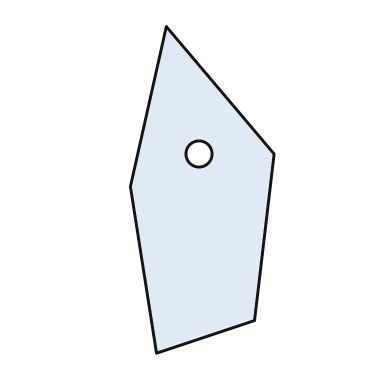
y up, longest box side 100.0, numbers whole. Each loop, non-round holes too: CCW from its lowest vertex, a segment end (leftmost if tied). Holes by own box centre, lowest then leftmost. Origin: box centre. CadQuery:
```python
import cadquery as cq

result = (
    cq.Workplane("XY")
    .moveTo(-14.0, -50.0)
    .lineTo(16.0, -40.0)
    .lineTo(22.0, 11.0)
    .lineTo(-11.0, 50.0)
    .lineTo(-22.0, 1.0)
    .close()
    .moveTo(-1.0, 11.0)
    .circle(4.0)
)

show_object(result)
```